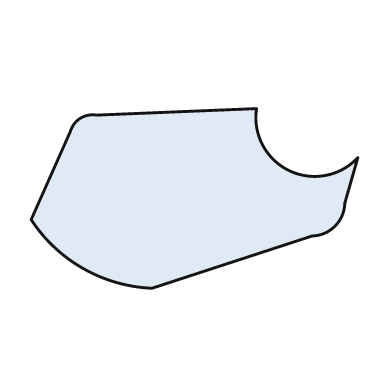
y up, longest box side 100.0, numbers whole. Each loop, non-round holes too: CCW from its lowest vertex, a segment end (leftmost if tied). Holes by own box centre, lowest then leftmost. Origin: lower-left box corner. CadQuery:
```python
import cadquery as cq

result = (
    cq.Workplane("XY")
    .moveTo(37.0, 0.0)
    .lineTo(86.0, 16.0)
    .threePointArc((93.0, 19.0), (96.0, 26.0))
    .lineTo(100.0, 40.0)
    .threePointArc((79.0, 36.0), (69.0, 55.0))
    .lineTo(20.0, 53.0)
    .threePointArc((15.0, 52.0), (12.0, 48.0))
    .lineTo(0.0, 21.0)
    .threePointArc((16.0, 6.0), (37.0, 0.0))
    .close()
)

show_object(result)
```